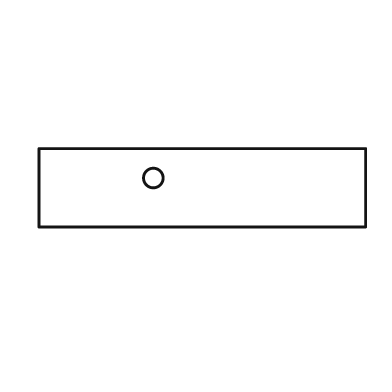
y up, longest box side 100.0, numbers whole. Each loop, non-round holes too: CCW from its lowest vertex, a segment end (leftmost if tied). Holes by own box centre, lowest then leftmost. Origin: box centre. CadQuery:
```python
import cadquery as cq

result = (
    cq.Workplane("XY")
    .moveTo(-50.0, -12.0)
    .lineTo(50.0, -12.0)
    .lineTo(50.0, 12.0)
    .lineTo(-50.0, 12.0)
    .close()
    .moveTo(-15.0, 3.0)
    .circle(3.0)
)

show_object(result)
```